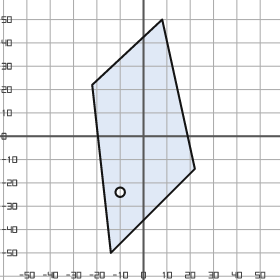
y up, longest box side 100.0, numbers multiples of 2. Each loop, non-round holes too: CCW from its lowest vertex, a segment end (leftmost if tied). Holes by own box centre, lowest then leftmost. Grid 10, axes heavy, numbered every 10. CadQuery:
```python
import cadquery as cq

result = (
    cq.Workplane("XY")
    .moveTo(-14.0, -50.0)
    .lineTo(22.0, -14.0)
    .lineTo(8.0, 50.0)
    .lineTo(-22.0, 22.0)
    .close()
    .moveTo(-10.0, -24.0)
    .circle(2.0)
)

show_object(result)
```